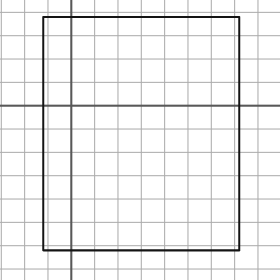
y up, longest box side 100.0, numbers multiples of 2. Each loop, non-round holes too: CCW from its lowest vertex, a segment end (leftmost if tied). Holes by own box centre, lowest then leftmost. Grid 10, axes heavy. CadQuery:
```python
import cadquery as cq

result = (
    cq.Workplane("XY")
    .moveTo(-12.0, -62.0)
    .lineTo(72.0, -62.0)
    .lineTo(72.0, 38.0)
    .lineTo(-12.0, 38.0)
    .close()
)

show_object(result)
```